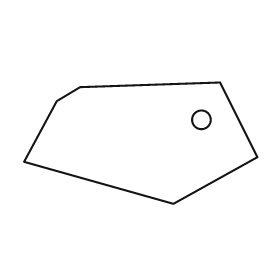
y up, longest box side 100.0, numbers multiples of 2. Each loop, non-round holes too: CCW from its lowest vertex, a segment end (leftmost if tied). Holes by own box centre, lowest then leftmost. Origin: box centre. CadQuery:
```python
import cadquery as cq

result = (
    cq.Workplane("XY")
    .moveTo(14.0, -26.0)
    .lineTo(50.0, -6.0)
    .lineTo(34.0, 26.0)
    .lineTo(-26.0, 24.0)
    .lineTo(-36.0, 18.0)
    .lineTo(-50.0, -8.0)
    .close()
    .moveTo(26.0, 10.0)
    .circle(4.0)
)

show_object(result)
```